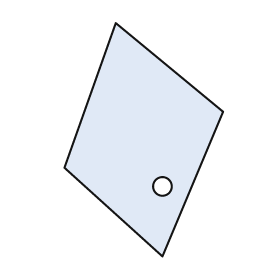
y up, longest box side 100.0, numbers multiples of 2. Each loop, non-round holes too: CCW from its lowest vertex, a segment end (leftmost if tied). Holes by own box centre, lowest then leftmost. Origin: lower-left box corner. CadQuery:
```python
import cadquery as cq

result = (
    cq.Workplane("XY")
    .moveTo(42.0, 0.0)
    .lineTo(68.0, 62.0)
    .lineTo(22.0, 100.0)
    .lineTo(0.0, 38.0)
    .close()
    .moveTo(42.0, 30.0)
    .circle(4.0)
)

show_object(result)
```